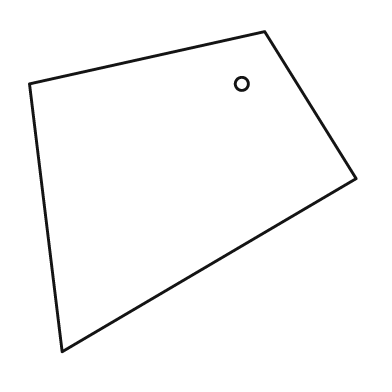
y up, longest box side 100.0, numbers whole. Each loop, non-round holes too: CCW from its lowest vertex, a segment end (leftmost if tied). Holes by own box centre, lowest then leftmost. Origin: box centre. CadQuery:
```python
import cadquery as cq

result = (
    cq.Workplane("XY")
    .moveTo(-40.0, -49.0)
    .lineTo(50.0, 4.0)
    .lineTo(22.0, 49.0)
    .lineTo(-50.0, 33.0)
    .close()
    .moveTo(15.0, 33.0)
    .circle(2.0)
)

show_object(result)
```